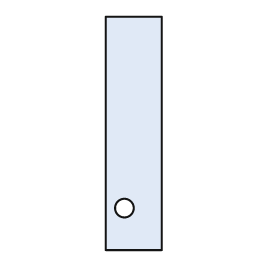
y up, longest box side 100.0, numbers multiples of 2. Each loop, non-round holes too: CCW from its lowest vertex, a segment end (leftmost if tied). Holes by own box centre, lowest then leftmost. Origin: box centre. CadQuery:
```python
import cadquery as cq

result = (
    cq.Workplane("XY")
    .moveTo(-12.0, -50.0)
    .lineTo(12.0, -50.0)
    .lineTo(12.0, 50.0)
    .lineTo(-12.0, 50.0)
    .close()
    .moveTo(-4.0, -32.0)
    .circle(4.0)
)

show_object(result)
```